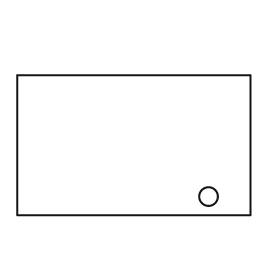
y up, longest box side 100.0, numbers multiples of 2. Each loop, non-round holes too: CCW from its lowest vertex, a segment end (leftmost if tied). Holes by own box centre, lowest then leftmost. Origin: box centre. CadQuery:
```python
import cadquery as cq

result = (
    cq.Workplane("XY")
    .moveTo(-50.0, -30.0)
    .lineTo(50.0, -30.0)
    .lineTo(50.0, 30.0)
    .lineTo(-50.0, 30.0)
    .close()
    .moveTo(32.0, -22.0)
    .circle(4.0)
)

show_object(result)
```